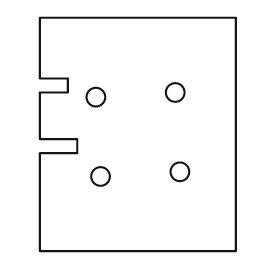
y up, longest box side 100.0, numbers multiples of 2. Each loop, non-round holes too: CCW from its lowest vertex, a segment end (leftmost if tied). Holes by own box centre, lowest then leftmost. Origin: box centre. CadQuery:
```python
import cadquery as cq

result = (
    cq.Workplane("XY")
    .moveTo(-42.0, -50.0)
    .lineTo(42.0, -50.0)
    .lineTo(42.0, 50.0)
    .lineTo(-42.0, 50.0)
    .lineTo(-42.0, 24.0)
    .lineTo(-30.0, 24.0)
    .lineTo(-30.0, 18.0)
    .lineTo(-42.0, 18.0)
    .lineTo(-42.0, -2.0)
    .lineTo(-26.0, -2.0)
    .lineTo(-26.0, -8.0)
    .lineTo(-42.0, -8.0)
    .close()
    .moveTo(-16.0, -18.0)
    .circle(4.0)
    .moveTo(18.0, -16.0)
    .circle(4.0)
    .moveTo(-18.0, 16.0)
    .circle(4.0)
    .moveTo(16.0, 18.0)
    .circle(4.0)
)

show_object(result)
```